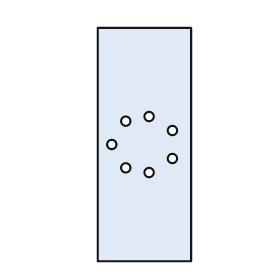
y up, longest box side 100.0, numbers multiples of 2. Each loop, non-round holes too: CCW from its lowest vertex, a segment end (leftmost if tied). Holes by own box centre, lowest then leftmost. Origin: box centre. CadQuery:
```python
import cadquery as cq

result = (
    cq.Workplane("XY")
    .moveTo(-20.0, -50.0)
    .lineTo(20.0, -50.0)
    .lineTo(20.0, 50.0)
    .lineTo(-20.0, 50.0)
    .close()
    .moveTo(2.0, -12.0)
    .circle(2.0)
    .moveTo(-8.0, -10.0)
    .circle(2.0)
    .moveTo(12.0, -6.0)
    .circle(2.0)
    .moveTo(-14.0, 0.0)
    .circle(2.0)
    .moveTo(12.0, 6.0)
    .circle(2.0)
    .moveTo(-8.0, 10.0)
    .circle(2.0)
    .moveTo(2.0, 12.0)
    .circle(2.0)
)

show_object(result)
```